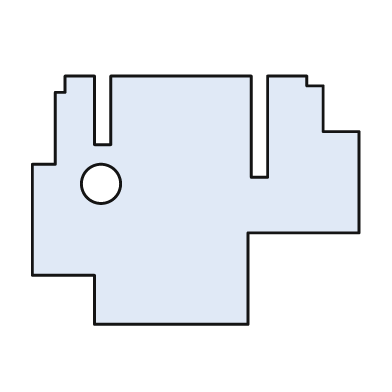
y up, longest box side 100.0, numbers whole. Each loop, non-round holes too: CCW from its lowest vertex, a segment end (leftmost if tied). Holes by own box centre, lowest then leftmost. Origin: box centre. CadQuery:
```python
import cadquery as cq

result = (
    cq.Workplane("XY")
    .moveTo(-31.0, -38.0)
    .lineTo(16.0, -38.0)
    .lineTo(16.0, -10.0)
    .lineTo(50.0, -10.0)
    .lineTo(50.0, 21.0)
    .lineTo(39.0, 21.0)
    .lineTo(39.0, 35.0)
    .lineTo(34.0, 35.0)
    .lineTo(34.0, 38.0)
    .lineTo(22.0, 38.0)
    .lineTo(22.0, 7.0)
    .lineTo(17.0, 7.0)
    .lineTo(17.0, 38.0)
    .lineTo(-26.0, 38.0)
    .lineTo(-26.0, 17.0)
    .lineTo(-31.0, 17.0)
    .lineTo(-31.0, 38.0)
    .lineTo(-40.0, 38.0)
    .lineTo(-40.0, 33.0)
    .lineTo(-43.0, 33.0)
    .lineTo(-43.0, 11.0)
    .lineTo(-50.0, 11.0)
    .lineTo(-50.0, -23.0)
    .lineTo(-31.0, -23.0)
    .close()
    .moveTo(-29.0, 5.0)
    .circle(6.0)
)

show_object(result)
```